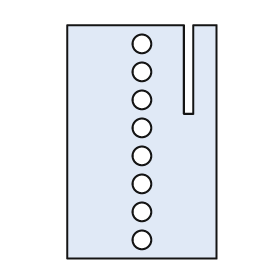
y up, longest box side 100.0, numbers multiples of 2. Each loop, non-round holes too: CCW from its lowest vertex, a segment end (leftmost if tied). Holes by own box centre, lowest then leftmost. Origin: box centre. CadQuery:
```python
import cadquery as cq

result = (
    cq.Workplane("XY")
    .moveTo(-32.0, -50.0)
    .lineTo(32.0, -50.0)
    .lineTo(32.0, 50.0)
    .lineTo(22.0, 50.0)
    .lineTo(22.0, 12.0)
    .lineTo(18.0, 12.0)
    .lineTo(18.0, 50.0)
    .lineTo(-32.0, 50.0)
    .close()
    .moveTo(0.0, -42.0)
    .circle(4.0)
    .moveTo(0.0, -30.0)
    .circle(4.0)
    .moveTo(0.0, -18.0)
    .circle(4.0)
    .moveTo(0.0, -6.0)
    .circle(4.0)
    .moveTo(0.0, 6.0)
    .circle(4.0)
    .moveTo(0.0, 18.0)
    .circle(4.0)
    .moveTo(0.0, 30.0)
    .circle(4.0)
    .moveTo(0.0, 42.0)
    .circle(4.0)
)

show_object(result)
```